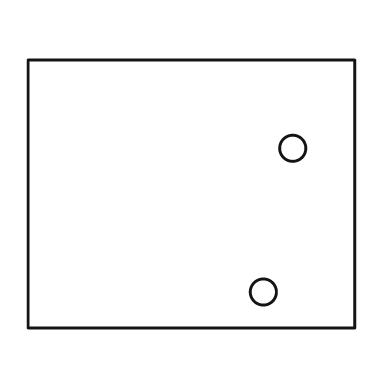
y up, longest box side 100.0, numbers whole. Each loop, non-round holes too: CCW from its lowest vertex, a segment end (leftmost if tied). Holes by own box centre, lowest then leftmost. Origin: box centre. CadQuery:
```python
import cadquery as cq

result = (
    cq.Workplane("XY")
    .moveTo(-50.0, -41.0)
    .lineTo(50.0, -41.0)
    .lineTo(50.0, 41.0)
    .lineTo(-50.0, 41.0)
    .close()
    .moveTo(22.0, -30.0)
    .circle(4.0)
    .moveTo(31.0, 14.0)
    .circle(4.0)
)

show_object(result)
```